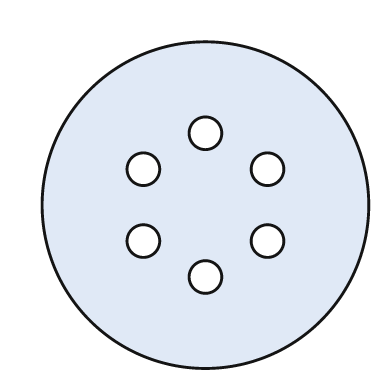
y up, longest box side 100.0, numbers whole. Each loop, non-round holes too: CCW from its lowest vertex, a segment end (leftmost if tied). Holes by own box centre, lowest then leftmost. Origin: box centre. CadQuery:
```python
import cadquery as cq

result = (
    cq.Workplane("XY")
    .moveTo(0.0, 0.0)
    .circle(50.0)
    .moveTo(0.0, -22.0)
    .circle(5.0)
    .moveTo(-19.0, -11.0)
    .circle(5.0)
    .moveTo(19.0, -11.0)
    .circle(5.0)
    .moveTo(-19.0, 11.0)
    .circle(5.0)
    .moveTo(19.0, 11.0)
    .circle(5.0)
    .moveTo(0.0, 22.0)
    .circle(5.0)
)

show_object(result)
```